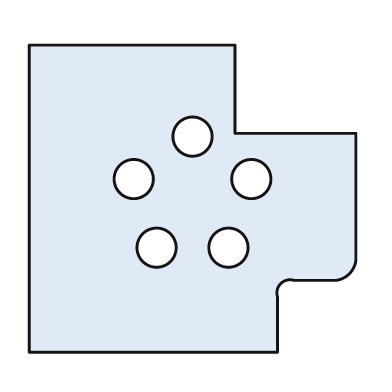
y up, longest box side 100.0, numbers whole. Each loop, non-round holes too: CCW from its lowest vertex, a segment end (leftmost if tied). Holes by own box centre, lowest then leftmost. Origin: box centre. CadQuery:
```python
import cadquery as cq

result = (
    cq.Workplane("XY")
    .moveTo(-50.0, -47.0)
    .lineTo(26.0, -47.0)
    .lineTo(26.0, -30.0)
    .threePointArc((27.0, -26.0), (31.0, -25.0))
    .lineTo(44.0, -25.0)
    .threePointArc((48.0, -23.0), (50.0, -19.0))
    .lineTo(50.0, 20.0)
    .lineTo(13.0, 20.0)
    .lineTo(13.0, 47.0)
    .lineTo(-50.0, 47.0)
    .close()
    .moveTo(-11.0, -15.0)
    .circle(6.0)
    .moveTo(11.0, -15.0)
    .circle(6.0)
    .moveTo(-18.0, 6.0)
    .circle(6.0)
    .moveTo(18.0, 6.0)
    .circle(6.0)
    .moveTo(0.0, 19.0)
    .circle(6.0)
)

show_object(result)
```